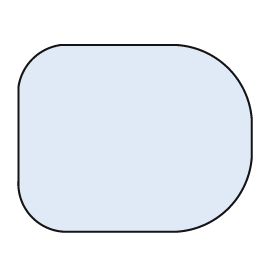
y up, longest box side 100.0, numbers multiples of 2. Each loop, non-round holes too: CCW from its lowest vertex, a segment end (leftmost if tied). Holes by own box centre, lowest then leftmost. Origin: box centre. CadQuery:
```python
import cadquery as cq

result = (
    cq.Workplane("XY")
    .moveTo(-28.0, -40.0)
    .lineTo(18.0, -40.0)
    .threePointArc((40.0, -30.0), (50.0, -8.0))
    .lineTo(50.0, 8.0)
    .threePointArc((40.0, 30.0), (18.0, 40.0))
    .lineTo(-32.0, 40.0)
    .threePointArc((-44.0, 34.0), (-50.0, 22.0))
    .lineTo(-50.0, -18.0)
    .threePointArc((-44.0, -34.0), (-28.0, -40.0))
    .close()
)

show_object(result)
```